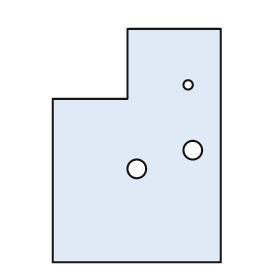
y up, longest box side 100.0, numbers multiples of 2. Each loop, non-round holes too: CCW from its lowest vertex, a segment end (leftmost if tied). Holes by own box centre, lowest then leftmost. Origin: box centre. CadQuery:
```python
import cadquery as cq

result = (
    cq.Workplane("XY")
    .moveTo(-36.0, -50.0)
    .lineTo(36.0, -50.0)
    .lineTo(36.0, 50.0)
    .lineTo(-4.0, 50.0)
    .lineTo(-4.0, 20.0)
    .lineTo(-36.0, 20.0)
    .close()
    .moveTo(0.0, -10.0)
    .circle(4.0)
    .moveTo(24.0, -2.0)
    .circle(4.0)
    .moveTo(22.0, 26.0)
    .circle(2.0)
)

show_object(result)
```